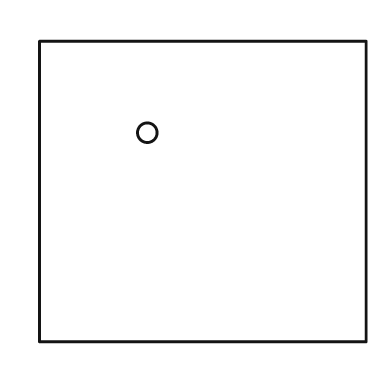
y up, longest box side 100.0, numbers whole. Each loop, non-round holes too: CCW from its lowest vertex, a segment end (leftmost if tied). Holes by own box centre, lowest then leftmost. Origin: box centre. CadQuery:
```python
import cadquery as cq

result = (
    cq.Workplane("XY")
    .moveTo(-50.0, -46.0)
    .lineTo(50.0, -46.0)
    .lineTo(50.0, 46.0)
    .lineTo(-50.0, 46.0)
    .close()
    .moveTo(-17.0, 18.0)
    .circle(3.0)
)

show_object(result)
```